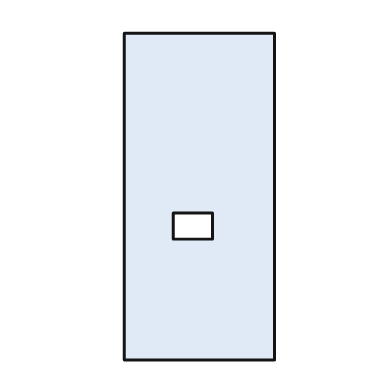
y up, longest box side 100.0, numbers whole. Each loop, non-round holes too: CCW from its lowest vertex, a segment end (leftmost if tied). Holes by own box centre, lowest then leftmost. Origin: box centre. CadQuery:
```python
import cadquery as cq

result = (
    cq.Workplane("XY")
    .moveTo(-23.0, -50.0)
    .lineTo(23.0, -50.0)
    .lineTo(23.0, 50.0)
    .lineTo(-23.0, 50.0)
    .close()
    .moveTo(-8.0, -13.0)
    .lineTo(4.0, -13.0)
    .lineTo(4.0, -5.0)
    .lineTo(-8.0, -5.0)
    .close()
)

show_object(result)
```